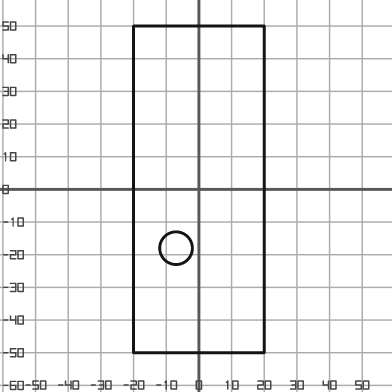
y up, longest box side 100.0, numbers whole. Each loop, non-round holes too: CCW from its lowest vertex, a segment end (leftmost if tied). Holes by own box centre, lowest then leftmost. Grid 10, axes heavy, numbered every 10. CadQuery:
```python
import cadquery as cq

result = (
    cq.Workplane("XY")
    .moveTo(-20.0, -50.0)
    .lineTo(20.0, -50.0)
    .lineTo(20.0, 50.0)
    .lineTo(-20.0, 50.0)
    .close()
    .moveTo(-7.0, -18.0)
    .circle(5.0)
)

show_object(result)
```